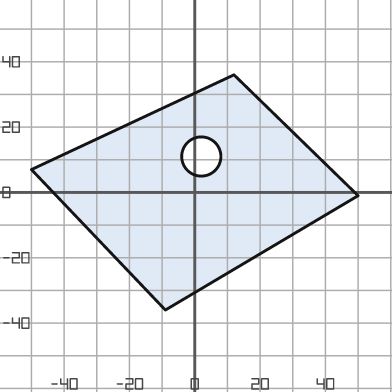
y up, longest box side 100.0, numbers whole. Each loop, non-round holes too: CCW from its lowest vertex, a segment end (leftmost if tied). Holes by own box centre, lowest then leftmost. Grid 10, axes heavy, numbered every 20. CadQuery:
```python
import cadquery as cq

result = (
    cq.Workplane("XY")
    .moveTo(-9.0, -36.0)
    .lineTo(50.0, -1.0)
    .lineTo(12.0, 36.0)
    .lineTo(-50.0, 7.0)
    .close()
    .moveTo(2.0, 11.0)
    .circle(6.0)
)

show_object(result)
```